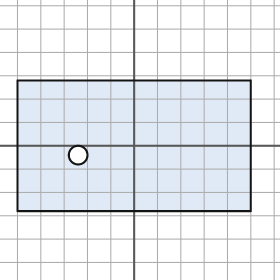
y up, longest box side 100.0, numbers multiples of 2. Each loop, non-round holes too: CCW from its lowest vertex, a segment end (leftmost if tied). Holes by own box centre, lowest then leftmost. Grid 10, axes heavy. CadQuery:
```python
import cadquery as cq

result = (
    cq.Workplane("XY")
    .moveTo(-50.0, -28.0)
    .lineTo(50.0, -28.0)
    .lineTo(50.0, 28.0)
    .lineTo(-50.0, 28.0)
    .close()
    .moveTo(-24.0, -4.0)
    .circle(4.0)
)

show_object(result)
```